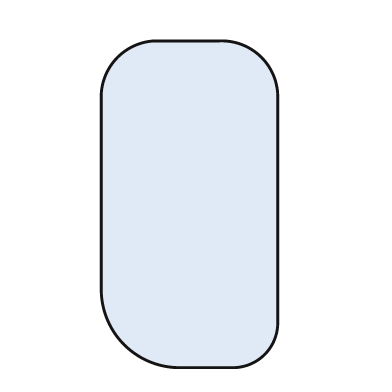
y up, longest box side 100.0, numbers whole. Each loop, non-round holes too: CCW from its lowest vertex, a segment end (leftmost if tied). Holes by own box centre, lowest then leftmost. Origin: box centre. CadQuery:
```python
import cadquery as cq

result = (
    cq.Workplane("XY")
    .moveTo(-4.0, -50.0)
    .lineTo(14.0, -50.0)
    .threePointArc((23.0, -46.0), (27.0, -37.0))
    .lineTo(27.0, 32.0)
    .threePointArc((22.0, 45.0), (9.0, 50.0))
    .lineTo(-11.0, 50.0)
    .threePointArc((-22.0, 45.0), (-27.0, 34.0))
    .lineTo(-27.0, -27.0)
    .threePointArc((-20.0, -43.0), (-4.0, -50.0))
    .close()
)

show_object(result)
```